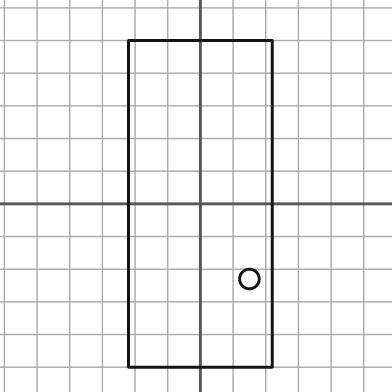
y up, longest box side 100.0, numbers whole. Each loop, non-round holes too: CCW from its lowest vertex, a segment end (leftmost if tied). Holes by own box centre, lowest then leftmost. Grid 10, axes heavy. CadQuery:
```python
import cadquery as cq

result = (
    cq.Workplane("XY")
    .moveTo(-22.0, -50.0)
    .lineTo(22.0, -50.0)
    .lineTo(22.0, 50.0)
    .lineTo(-22.0, 50.0)
    .close()
    .moveTo(15.0, -23.0)
    .circle(3.0)
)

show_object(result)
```